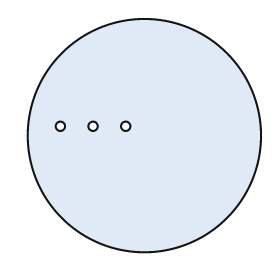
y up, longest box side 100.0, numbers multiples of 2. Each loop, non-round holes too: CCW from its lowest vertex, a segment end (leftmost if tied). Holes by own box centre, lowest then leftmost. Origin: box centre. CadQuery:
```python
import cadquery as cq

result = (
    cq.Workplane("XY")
    .moveTo(0.0, 0.0)
    .circle(50.0)
    .moveTo(-36.0, 4.0)
    .circle(2.0)
    .moveTo(-22.0, 4.0)
    .circle(2.0)
    .moveTo(-8.0, 4.0)
    .circle(2.0)
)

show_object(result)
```